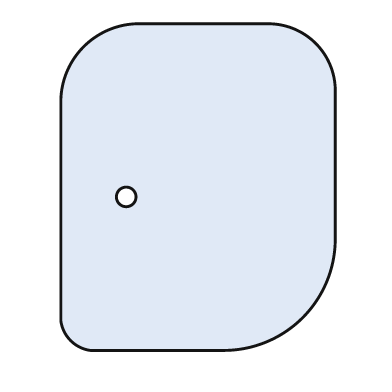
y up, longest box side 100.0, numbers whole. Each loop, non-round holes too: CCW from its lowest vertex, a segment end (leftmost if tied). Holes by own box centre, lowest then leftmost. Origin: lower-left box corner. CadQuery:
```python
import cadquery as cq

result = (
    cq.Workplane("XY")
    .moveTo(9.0, 0.0)
    .lineTo(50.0, 0.0)
    .threePointArc((74.0, 10.0), (84.0, 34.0))
    .lineTo(84.0, 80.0)
    .threePointArc((78.0, 94.0), (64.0, 100.0))
    .lineTo(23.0, 100.0)
    .threePointArc((7.0, 93.0), (0.0, 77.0))
    .lineTo(0.0, 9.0)
    .threePointArc((3.0, 3.0), (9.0, 0.0))
    .close()
    .moveTo(20.0, 47.0)
    .circle(3.0)
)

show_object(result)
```